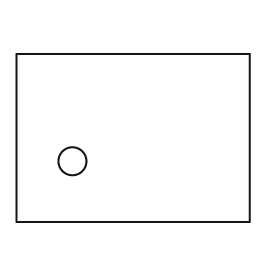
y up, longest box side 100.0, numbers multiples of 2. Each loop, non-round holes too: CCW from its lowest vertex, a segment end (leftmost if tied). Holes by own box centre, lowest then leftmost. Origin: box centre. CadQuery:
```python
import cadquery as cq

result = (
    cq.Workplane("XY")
    .moveTo(-50.0, -36.0)
    .lineTo(50.0, -36.0)
    .lineTo(50.0, 36.0)
    .lineTo(-50.0, 36.0)
    .close()
    .moveTo(-26.0, -10.0)
    .circle(6.0)
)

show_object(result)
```